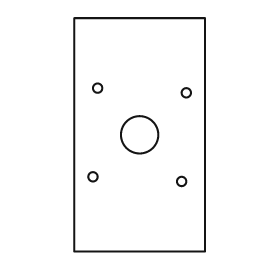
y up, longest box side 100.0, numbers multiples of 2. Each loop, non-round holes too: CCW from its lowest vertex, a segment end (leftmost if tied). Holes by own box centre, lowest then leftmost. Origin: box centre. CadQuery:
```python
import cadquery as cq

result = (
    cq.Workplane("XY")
    .moveTo(-28.0, -50.0)
    .lineTo(28.0, -50.0)
    .lineTo(28.0, 50.0)
    .lineTo(-28.0, 50.0)
    .close()
    .moveTo(18.0, -20.0)
    .circle(2.0)
    .moveTo(-20.0, -18.0)
    .circle(2.0)
    .moveTo(0.0, 0.0)
    .circle(8.0)
    .moveTo(20.0, 18.0)
    .circle(2.0)
    .moveTo(-18.0, 20.0)
    .circle(2.0)
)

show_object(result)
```